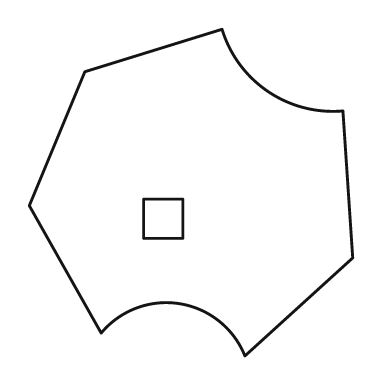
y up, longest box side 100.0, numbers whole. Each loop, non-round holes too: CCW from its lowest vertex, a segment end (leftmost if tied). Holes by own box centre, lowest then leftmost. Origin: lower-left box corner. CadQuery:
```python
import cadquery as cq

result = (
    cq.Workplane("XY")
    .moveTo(66.0, 0.0)
    .lineTo(99.0, 30.0)
    .lineTo(96.0, 75.0)
    .threePointArc((73.0, 81.0), (59.0, 100.0))
    .lineTo(17.0, 87.0)
    .lineTo(0.0, 46.0)
    .lineTo(22.0, 7.0)
    .threePointArc((46.0, 16.0), (66.0, 0.0))
    .close()
    .moveTo(35.0, 36.0)
    .lineTo(47.0, 36.0)
    .lineTo(47.0, 48.0)
    .lineTo(35.0, 48.0)
    .close()
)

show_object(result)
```